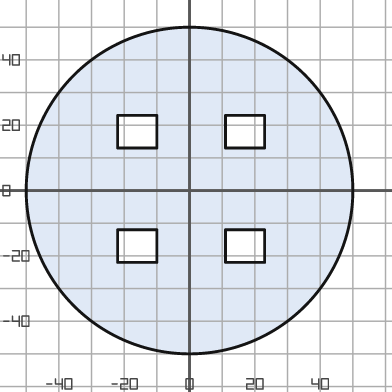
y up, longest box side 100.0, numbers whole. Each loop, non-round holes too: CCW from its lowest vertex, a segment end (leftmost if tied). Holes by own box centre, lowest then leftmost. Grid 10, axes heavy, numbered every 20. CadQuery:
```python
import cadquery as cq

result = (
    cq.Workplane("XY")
    .moveTo(0.0, 0.0)
    .circle(50.0)
    .moveTo(-22.0, -22.0)
    .lineTo(-10.0, -22.0)
    .lineTo(-10.0, -12.0)
    .lineTo(-22.0, -12.0)
    .close()
    .moveTo(11.0, -22.0)
    .lineTo(23.0, -22.0)
    .lineTo(23.0, -12.0)
    .lineTo(11.0, -12.0)
    .close()
    .moveTo(-22.0, 13.0)
    .lineTo(-10.0, 13.0)
    .lineTo(-10.0, 23.0)
    .lineTo(-22.0, 23.0)
    .close()
    .moveTo(11.0, 13.0)
    .lineTo(23.0, 13.0)
    .lineTo(23.0, 23.0)
    .lineTo(11.0, 23.0)
    .close()
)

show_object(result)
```